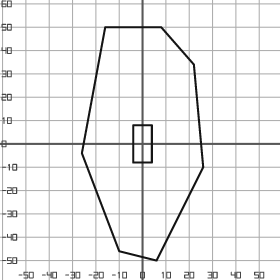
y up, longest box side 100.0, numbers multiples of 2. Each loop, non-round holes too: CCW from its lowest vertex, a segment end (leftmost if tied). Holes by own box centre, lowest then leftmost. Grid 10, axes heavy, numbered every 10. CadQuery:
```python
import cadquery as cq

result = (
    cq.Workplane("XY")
    .moveTo(6.0, -50.0)
    .lineTo(26.0, -10.0)
    .lineTo(22.0, 34.0)
    .lineTo(8.0, 50.0)
    .lineTo(-16.0, 50.0)
    .lineTo(-26.0, -4.0)
    .lineTo(-10.0, -46.0)
    .close()
    .moveTo(-4.0, -8.0)
    .lineTo(4.0, -8.0)
    .lineTo(4.0, 8.0)
    .lineTo(-4.0, 8.0)
    .close()
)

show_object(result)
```